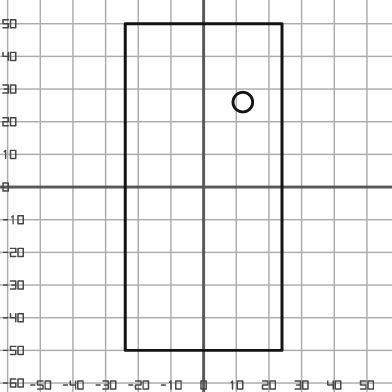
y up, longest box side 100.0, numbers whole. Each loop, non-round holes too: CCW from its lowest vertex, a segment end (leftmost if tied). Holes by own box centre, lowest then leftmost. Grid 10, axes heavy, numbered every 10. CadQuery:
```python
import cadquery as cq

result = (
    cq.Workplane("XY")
    .moveTo(-24.0, -50.0)
    .lineTo(24.0, -50.0)
    .lineTo(24.0, 50.0)
    .lineTo(-24.0, 50.0)
    .close()
    .moveTo(12.0, 26.0)
    .circle(3.0)
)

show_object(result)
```